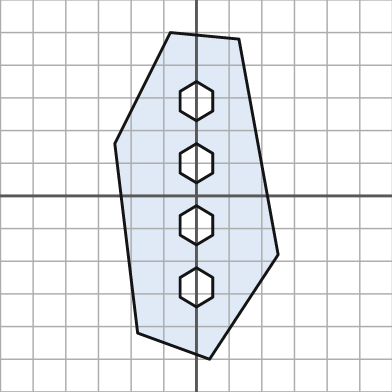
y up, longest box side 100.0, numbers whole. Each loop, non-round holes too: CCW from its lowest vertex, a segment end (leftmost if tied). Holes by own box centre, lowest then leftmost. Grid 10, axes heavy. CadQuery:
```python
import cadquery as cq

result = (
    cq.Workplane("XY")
    .moveTo(4.0, -50.0)
    .lineTo(25.0, -18.0)
    .lineTo(13.0, 48.0)
    .lineTo(-8.0, 50.0)
    .lineTo(-25.0, 16.0)
    .lineTo(-18.0, -42.0)
    .close()
    .moveTo(0.0, -34.0)
    .lineTo(5.0, -31.0)
    .lineTo(5.0, -25.0)
    .lineTo(0.0, -22.0)
    .lineTo(-5.0, -25.0)
    .lineTo(-5.0, -31.0)
    .close()
    .moveTo(0.0, -15.0)
    .lineTo(5.0, -12.0)
    .lineTo(5.0, -6.0)
    .lineTo(0.0, -3.0)
    .lineTo(-5.0, -6.0)
    .lineTo(-5.0, -12.0)
    .close()
    .moveTo(0.0, 4.0)
    .lineTo(5.0, 7.0)
    .lineTo(5.0, 13.0)
    .lineTo(0.0, 16.0)
    .lineTo(-5.0, 13.0)
    .lineTo(-5.0, 7.0)
    .close()
    .moveTo(0.0, 23.0)
    .lineTo(5.0, 26.0)
    .lineTo(5.0, 32.0)
    .lineTo(0.0, 35.0)
    .lineTo(-5.0, 32.0)
    .lineTo(-5.0, 26.0)
    .close()
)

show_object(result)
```